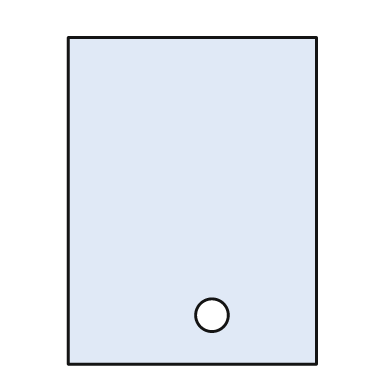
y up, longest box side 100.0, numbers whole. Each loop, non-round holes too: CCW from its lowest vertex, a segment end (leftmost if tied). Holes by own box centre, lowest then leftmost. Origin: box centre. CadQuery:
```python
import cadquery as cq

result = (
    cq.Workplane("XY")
    .moveTo(-38.0, -50.0)
    .lineTo(38.0, -50.0)
    .lineTo(38.0, 50.0)
    .lineTo(-38.0, 50.0)
    .close()
    .moveTo(6.0, -35.0)
    .circle(5.0)
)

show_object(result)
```